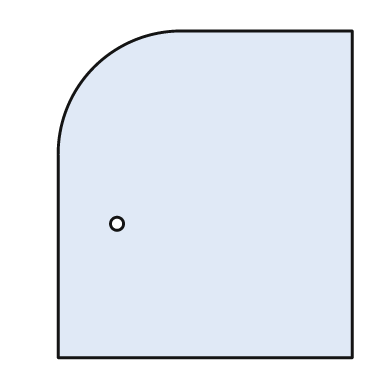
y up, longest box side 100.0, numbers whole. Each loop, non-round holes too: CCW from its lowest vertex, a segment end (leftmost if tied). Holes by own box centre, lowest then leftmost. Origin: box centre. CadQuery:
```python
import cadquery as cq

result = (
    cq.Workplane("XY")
    .moveTo(-45.0, -50.0)
    .lineTo(45.0, -50.0)
    .lineTo(45.0, 50.0)
    .lineTo(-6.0, 50.0)
    .threePointArc((-34.0, 39.0), (-45.0, 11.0))
    .close()
    .moveTo(-27.0, -9.0)
    .circle(2.0)
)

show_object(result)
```